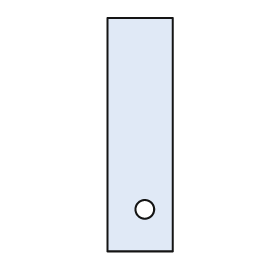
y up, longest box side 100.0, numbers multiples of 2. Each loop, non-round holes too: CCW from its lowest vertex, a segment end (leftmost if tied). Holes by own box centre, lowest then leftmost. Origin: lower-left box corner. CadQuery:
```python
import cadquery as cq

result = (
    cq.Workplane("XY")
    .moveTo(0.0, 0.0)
    .lineTo(28.0, 0.0)
    .lineTo(28.0, 100.0)
    .lineTo(0.0, 100.0)
    .close()
    .moveTo(16.0, 18.0)
    .circle(4.0)
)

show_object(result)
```